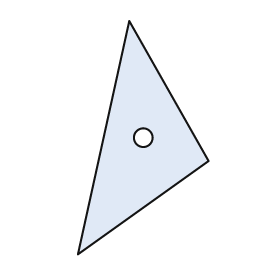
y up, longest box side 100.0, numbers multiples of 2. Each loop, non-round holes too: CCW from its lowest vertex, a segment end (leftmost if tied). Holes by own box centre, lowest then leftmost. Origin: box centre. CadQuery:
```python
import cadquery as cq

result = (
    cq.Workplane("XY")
    .moveTo(-28.0, -50.0)
    .lineTo(28.0, -10.0)
    .lineTo(-6.0, 50.0)
    .close()
    .moveTo(0.0, 0.0)
    .circle(4.0)
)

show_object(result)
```